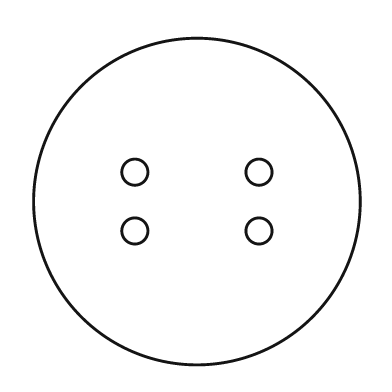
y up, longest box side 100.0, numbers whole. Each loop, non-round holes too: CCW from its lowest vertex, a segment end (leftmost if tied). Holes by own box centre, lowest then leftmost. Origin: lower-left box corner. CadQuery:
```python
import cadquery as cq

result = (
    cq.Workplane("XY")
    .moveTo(50.0, 50.0)
    .circle(50.0)
    .moveTo(31.0, 41.0)
    .circle(4.0)
    .moveTo(69.0, 41.0)
    .circle(4.0)
    .moveTo(31.0, 59.0)
    .circle(4.0)
    .moveTo(69.0, 59.0)
    .circle(4.0)
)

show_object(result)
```